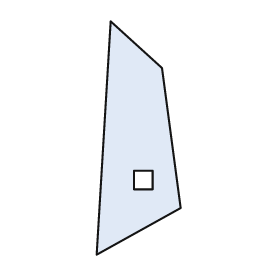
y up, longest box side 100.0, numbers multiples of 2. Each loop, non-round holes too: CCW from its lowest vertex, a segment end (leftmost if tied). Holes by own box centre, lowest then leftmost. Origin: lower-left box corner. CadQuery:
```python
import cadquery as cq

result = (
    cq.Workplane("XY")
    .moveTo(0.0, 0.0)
    .lineTo(36.0, 20.0)
    .lineTo(28.0, 80.0)
    .lineTo(6.0, 100.0)
    .close()
    .moveTo(16.0, 28.0)
    .lineTo(24.0, 28.0)
    .lineTo(24.0, 36.0)
    .lineTo(16.0, 36.0)
    .close()
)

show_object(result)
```